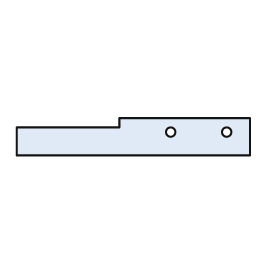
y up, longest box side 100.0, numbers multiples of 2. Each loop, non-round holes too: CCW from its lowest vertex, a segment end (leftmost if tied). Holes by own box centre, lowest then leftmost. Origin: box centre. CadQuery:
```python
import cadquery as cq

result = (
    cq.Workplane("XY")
    .moveTo(-50.0, -8.0)
    .lineTo(50.0, -8.0)
    .lineTo(50.0, 8.0)
    .lineTo(-6.0, 8.0)
    .lineTo(-6.0, 4.0)
    .lineTo(-50.0, 4.0)
    .close()
    .moveTo(16.0, 2.0)
    .circle(2.0)
    .moveTo(40.0, 2.0)
    .circle(2.0)
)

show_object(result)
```